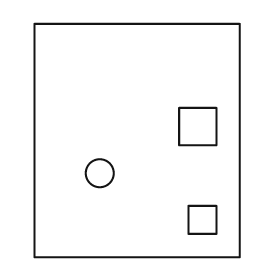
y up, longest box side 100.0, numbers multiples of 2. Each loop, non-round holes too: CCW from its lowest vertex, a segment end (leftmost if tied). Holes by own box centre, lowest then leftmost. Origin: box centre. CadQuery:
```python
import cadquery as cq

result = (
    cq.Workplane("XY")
    .moveTo(-44.0, -50.0)
    .lineTo(44.0, -50.0)
    .lineTo(44.0, 50.0)
    .lineTo(-44.0, 50.0)
    .close()
    .moveTo(22.0, -40.0)
    .lineTo(34.0, -40.0)
    .lineTo(34.0, -28.0)
    .lineTo(22.0, -28.0)
    .close()
    .moveTo(-16.0, -14.0)
    .circle(6.0)
    .moveTo(18.0, -2.0)
    .lineTo(34.0, -2.0)
    .lineTo(34.0, 14.0)
    .lineTo(18.0, 14.0)
    .close()
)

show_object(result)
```